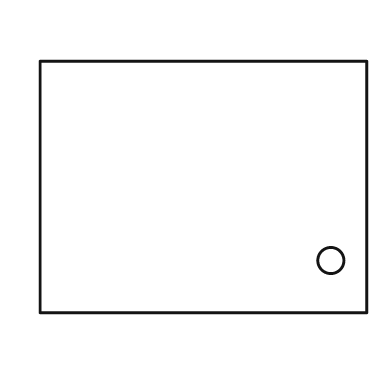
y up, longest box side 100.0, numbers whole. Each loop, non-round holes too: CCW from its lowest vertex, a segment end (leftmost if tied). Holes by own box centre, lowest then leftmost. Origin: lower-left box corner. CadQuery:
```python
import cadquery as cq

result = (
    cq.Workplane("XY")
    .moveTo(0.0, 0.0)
    .lineTo(100.0, 0.0)
    .lineTo(100.0, 77.0)
    .lineTo(0.0, 77.0)
    .close()
    .moveTo(89.0, 16.0)
    .circle(4.0)
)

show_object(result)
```